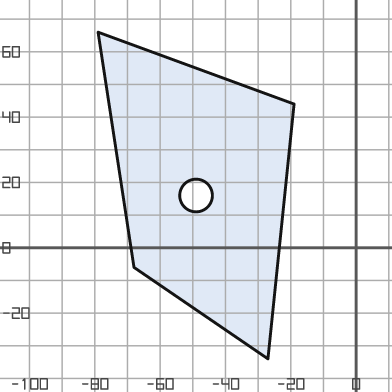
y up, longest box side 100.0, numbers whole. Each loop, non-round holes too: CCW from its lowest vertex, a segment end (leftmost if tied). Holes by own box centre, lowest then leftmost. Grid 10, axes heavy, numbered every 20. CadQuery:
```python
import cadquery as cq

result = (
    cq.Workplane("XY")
    .moveTo(-27.0, -34.0)
    .lineTo(-19.0, 44.0)
    .lineTo(-79.0, 66.0)
    .lineTo(-68.0, -6.0)
    .close()
    .moveTo(-49.0, 16.0)
    .circle(5.0)
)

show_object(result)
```